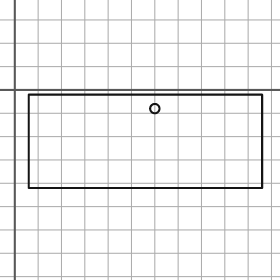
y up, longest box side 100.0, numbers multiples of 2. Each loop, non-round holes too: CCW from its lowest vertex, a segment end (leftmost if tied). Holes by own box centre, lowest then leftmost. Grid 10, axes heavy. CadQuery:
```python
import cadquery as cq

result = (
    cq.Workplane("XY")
    .moveTo(6.0, -42.0)
    .lineTo(106.0, -42.0)
    .lineTo(106.0, -2.0)
    .lineTo(6.0, -2.0)
    .close()
    .moveTo(60.0, -8.0)
    .circle(2.0)
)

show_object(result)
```